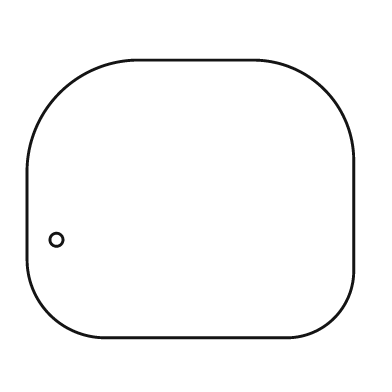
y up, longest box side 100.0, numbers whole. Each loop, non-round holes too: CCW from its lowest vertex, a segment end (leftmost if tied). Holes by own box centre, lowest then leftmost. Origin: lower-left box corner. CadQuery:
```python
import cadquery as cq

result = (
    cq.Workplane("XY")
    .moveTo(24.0, 0.0)
    .lineTo(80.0, 0.0)
    .threePointArc((94.0, 6.0), (100.0, 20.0))
    .lineTo(100.0, 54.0)
    .threePointArc((91.0, 76.0), (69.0, 85.0))
    .lineTo(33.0, 85.0)
    .threePointArc((10.0, 75.0), (0.0, 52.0))
    .lineTo(0.0, 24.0)
    .threePointArc((7.0, 7.0), (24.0, 0.0))
    .close()
    .moveTo(9.0, 30.0)
    .circle(2.0)
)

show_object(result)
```